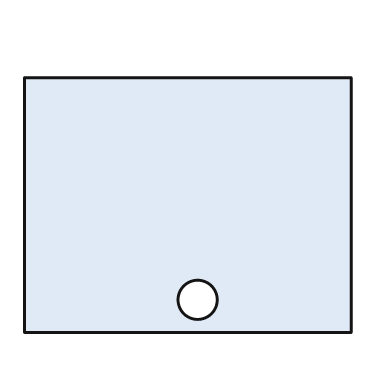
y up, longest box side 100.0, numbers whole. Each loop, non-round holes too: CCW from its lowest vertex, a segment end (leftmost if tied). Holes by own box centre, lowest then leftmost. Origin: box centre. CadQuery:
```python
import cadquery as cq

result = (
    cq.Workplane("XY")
    .moveTo(-50.0, -39.0)
    .lineTo(50.0, -39.0)
    .lineTo(50.0, 39.0)
    .lineTo(-50.0, 39.0)
    .close()
    .moveTo(3.0, -29.0)
    .circle(6.0)
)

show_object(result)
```